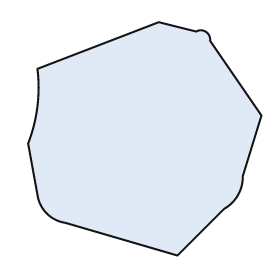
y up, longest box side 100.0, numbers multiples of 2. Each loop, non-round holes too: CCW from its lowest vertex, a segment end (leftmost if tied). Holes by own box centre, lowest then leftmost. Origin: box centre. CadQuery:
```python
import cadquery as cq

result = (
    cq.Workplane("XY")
    .moveTo(14.0, -50.0)
    .lineTo(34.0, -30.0)
    .threePointArc((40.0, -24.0), (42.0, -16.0))
    .lineTo(50.0, 10.0)
    .lineTo(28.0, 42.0)
    .threePointArc((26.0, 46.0), (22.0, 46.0))
    .lineTo(6.0, 50.0)
    .lineTo(-46.0, 30.0)
    .threePointArc((-46.0, 14.0), (-50.0, -2.0))
    .lineTo(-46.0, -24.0)
    .threePointArc((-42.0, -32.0), (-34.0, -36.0))
    .close()
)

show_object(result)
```